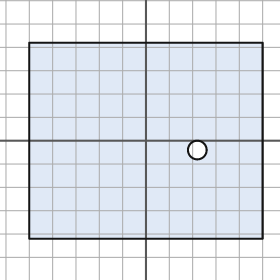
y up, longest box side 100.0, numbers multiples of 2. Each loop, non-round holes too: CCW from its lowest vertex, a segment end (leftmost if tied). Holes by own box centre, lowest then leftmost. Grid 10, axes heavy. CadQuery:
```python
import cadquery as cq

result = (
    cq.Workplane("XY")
    .moveTo(-50.0, -42.0)
    .lineTo(50.0, -42.0)
    .lineTo(50.0, 42.0)
    .lineTo(-50.0, 42.0)
    .close()
    .moveTo(22.0, -4.0)
    .circle(4.0)
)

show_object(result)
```